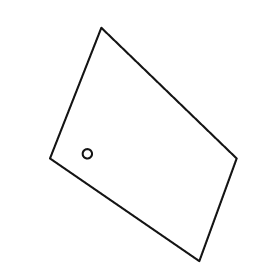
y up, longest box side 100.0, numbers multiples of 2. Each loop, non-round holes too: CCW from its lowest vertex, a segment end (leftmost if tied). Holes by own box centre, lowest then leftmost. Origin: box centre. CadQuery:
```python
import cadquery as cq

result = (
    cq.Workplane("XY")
    .moveTo(24.0, -50.0)
    .lineTo(40.0, -6.0)
    .lineTo(-18.0, 50.0)
    .lineTo(-40.0, -6.0)
    .close()
    .moveTo(-24.0, -4.0)
    .circle(2.0)
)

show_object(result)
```